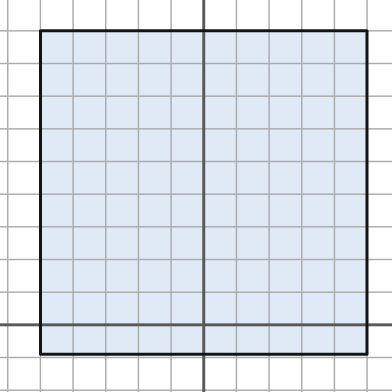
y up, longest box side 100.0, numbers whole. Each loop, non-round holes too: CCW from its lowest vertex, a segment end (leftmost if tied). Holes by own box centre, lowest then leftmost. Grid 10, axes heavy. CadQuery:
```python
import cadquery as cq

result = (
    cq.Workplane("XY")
    .moveTo(-50.0, -9.0)
    .lineTo(50.0, -9.0)
    .lineTo(50.0, 90.0)
    .lineTo(-50.0, 90.0)
    .close()
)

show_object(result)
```